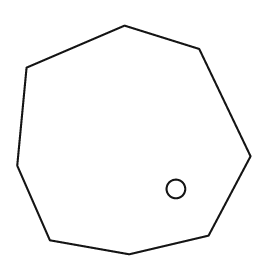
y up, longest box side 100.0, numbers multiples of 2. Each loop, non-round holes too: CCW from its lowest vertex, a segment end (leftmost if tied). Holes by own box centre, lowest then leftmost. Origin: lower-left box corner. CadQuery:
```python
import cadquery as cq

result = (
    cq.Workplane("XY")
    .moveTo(48.0, 0.0)
    .lineTo(82.0, 8.0)
    .lineTo(100.0, 42.0)
    .lineTo(78.0, 88.0)
    .lineTo(46.0, 98.0)
    .lineTo(4.0, 80.0)
    .lineTo(0.0, 38.0)
    .lineTo(14.0, 6.0)
    .close()
    .moveTo(68.0, 28.0)
    .circle(4.0)
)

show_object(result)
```